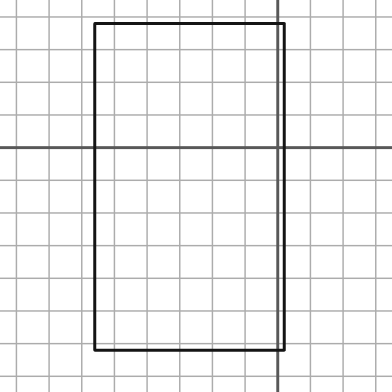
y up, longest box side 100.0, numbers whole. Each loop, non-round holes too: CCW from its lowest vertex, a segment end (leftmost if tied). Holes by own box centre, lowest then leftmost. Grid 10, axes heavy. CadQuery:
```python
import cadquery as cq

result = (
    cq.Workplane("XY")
    .moveTo(-56.0, -62.0)
    .lineTo(2.0, -62.0)
    .lineTo(2.0, 38.0)
    .lineTo(-56.0, 38.0)
    .close()
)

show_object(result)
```